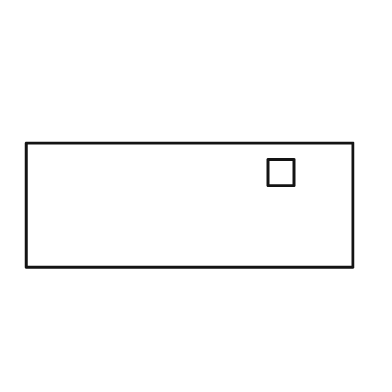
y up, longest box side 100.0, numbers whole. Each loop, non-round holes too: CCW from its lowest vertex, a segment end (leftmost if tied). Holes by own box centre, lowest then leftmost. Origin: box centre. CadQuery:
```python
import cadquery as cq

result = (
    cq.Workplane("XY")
    .moveTo(-50.0, -19.0)
    .lineTo(50.0, -19.0)
    .lineTo(50.0, 19.0)
    .lineTo(-50.0, 19.0)
    .close()
    .moveTo(24.0, 6.0)
    .lineTo(32.0, 6.0)
    .lineTo(32.0, 14.0)
    .lineTo(24.0, 14.0)
    .close()
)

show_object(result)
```